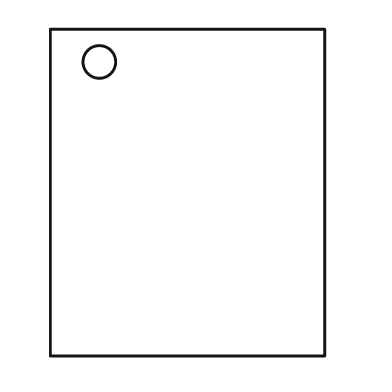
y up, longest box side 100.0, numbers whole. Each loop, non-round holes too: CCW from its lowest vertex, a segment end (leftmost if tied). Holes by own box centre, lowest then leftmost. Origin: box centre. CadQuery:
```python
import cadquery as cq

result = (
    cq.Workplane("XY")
    .moveTo(-42.0, -50.0)
    .lineTo(42.0, -50.0)
    .lineTo(42.0, 50.0)
    .lineTo(-42.0, 50.0)
    .close()
    .moveTo(-27.0, 40.0)
    .circle(5.0)
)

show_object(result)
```